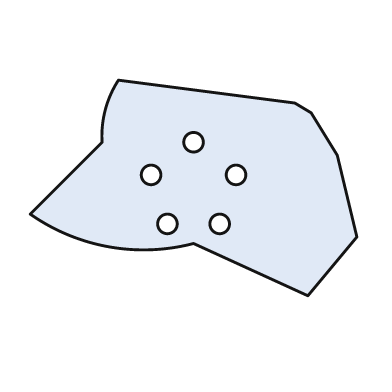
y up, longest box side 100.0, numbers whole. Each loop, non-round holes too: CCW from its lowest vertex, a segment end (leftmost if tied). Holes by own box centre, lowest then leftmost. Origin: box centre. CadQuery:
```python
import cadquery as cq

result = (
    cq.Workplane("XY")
    .moveTo(35.0, -33.0)
    .lineTo(50.0, -15.0)
    .lineTo(44.0, 10.0)
    .lineTo(36.0, 23.0)
    .lineTo(31.0, 26.0)
    .lineTo(-23.0, 33.0)
    .threePointArc((-27.0, 24.0), (-28.0, 14.0))
    .lineTo(-50.0, -8.0)
    .threePointArc((-26.0, -18.0), (0.0, -17.0))
    .close()
    .moveTo(-8.0, -11.0)
    .circle(3.0)
    .moveTo(8.0, -11.0)
    .circle(3.0)
    .moveTo(-13.0, 4.0)
    .circle(3.0)
    .moveTo(13.0, 4.0)
    .circle(3.0)
    .moveTo(0.0, 14.0)
    .circle(3.0)
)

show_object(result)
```